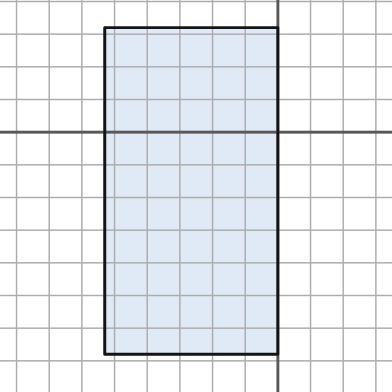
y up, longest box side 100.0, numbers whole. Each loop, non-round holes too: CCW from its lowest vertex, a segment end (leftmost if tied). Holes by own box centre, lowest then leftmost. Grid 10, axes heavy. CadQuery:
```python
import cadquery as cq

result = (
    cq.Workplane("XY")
    .moveTo(-53.0, -68.0)
    .lineTo(0.0, -68.0)
    .lineTo(0.0, 32.0)
    .lineTo(-53.0, 32.0)
    .close()
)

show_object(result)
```